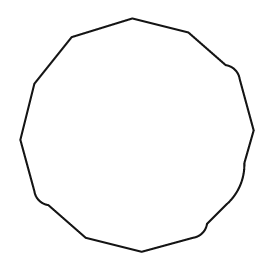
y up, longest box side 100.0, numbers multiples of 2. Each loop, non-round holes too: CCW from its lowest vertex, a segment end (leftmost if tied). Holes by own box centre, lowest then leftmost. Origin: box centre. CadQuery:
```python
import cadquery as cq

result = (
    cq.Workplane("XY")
    .moveTo(2.0, -50.0)
    .lineTo(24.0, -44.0)
    .threePointArc((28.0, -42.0), (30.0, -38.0))
    .lineTo(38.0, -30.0)
    .threePointArc((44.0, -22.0), (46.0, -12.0))
    .lineTo(50.0, 2.0)
    .lineTo(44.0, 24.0)
    .threePointArc((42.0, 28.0), (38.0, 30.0))
    .lineTo(22.0, 44.0)
    .lineTo(-2.0, 50.0)
    .lineTo(-28.0, 42.0)
    .lineTo(-44.0, 22.0)
    .lineTo(-50.0, -2.0)
    .lineTo(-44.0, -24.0)
    .threePointArc((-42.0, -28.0), (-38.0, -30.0))
    .lineTo(-22.0, -44.0)
    .close()
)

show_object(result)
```